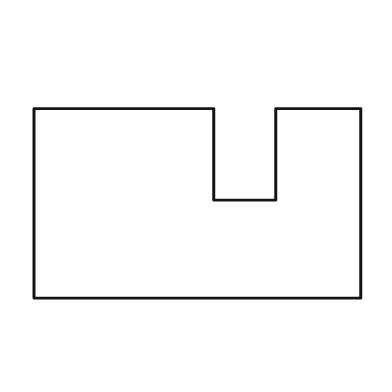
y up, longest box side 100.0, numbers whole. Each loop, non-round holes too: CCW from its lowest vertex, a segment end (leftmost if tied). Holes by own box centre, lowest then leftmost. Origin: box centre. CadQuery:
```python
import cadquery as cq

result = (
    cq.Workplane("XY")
    .moveTo(-50.0, -29.0)
    .lineTo(50.0, -29.0)
    .lineTo(50.0, 29.0)
    .lineTo(24.0, 29.0)
    .lineTo(24.0, 1.0)
    .lineTo(5.0, 1.0)
    .lineTo(5.0, 29.0)
    .lineTo(-50.0, 29.0)
    .close()
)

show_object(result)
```